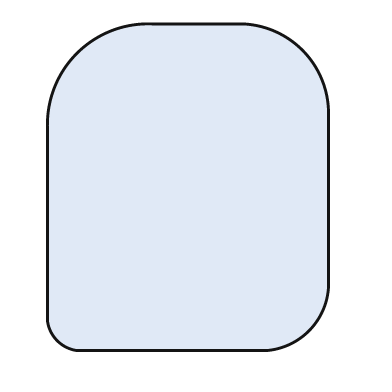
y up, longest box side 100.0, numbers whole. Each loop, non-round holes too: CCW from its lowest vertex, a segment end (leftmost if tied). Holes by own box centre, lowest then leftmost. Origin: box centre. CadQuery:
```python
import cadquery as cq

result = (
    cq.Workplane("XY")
    .moveTo(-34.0, -50.0)
    .lineTo(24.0, -50.0)
    .threePointArc((37.0, -44.0), (43.0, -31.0))
    .lineTo(43.0, 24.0)
    .threePointArc((35.0, 42.0), (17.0, 50.0))
    .lineTo(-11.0, 50.0)
    .threePointArc((-34.0, 41.0), (-43.0, 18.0))
    .lineTo(-43.0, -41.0)
    .threePointArc((-40.0, -47.0), (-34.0, -50.0))
    .close()
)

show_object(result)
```